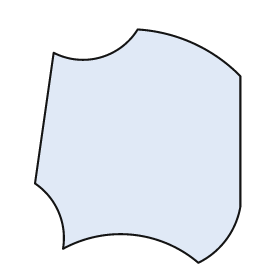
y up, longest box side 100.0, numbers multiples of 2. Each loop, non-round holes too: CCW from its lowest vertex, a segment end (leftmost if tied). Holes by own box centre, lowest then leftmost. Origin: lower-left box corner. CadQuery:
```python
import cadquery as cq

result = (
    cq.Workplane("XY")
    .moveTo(70.0, 0.0)
    .threePointArc((82.0, 10.0), (88.0, 24.0))
    .lineTo(88.0, 80.0)
    .threePointArc((68.0, 94.0), (44.0, 100.0))
    .threePointArc((28.0, 88.0), (8.0, 90.0))
    .lineTo(0.0, 34.0)
    .threePointArc((10.0, 22.0), (12.0, 6.0))
    .threePointArc((42.0, 12.0), (70.0, 0.0))
    .close()
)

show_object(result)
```